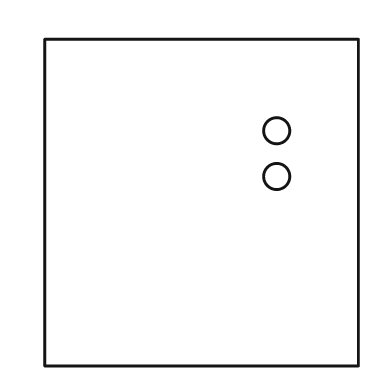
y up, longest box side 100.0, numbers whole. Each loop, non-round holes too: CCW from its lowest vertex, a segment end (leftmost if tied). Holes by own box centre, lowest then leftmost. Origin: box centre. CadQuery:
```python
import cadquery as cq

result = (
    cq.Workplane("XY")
    .moveTo(-48.0, -50.0)
    .lineTo(48.0, -50.0)
    .lineTo(48.0, 50.0)
    .lineTo(-48.0, 50.0)
    .close()
    .moveTo(23.0, 8.0)
    .circle(4.0)
    .moveTo(23.0, 22.0)
    .circle(4.0)
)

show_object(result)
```